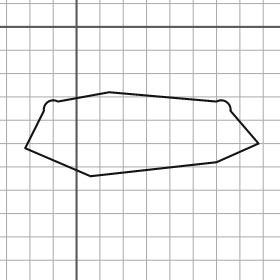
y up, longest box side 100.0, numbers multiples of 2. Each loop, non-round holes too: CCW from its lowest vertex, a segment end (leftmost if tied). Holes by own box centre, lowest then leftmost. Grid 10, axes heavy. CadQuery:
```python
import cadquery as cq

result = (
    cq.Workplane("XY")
    .moveTo(6.0, -64.0)
    .lineTo(60.0, -58.0)
    .lineTo(78.0, -50.0)
    .lineTo(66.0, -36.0)
    .threePointArc((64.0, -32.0), (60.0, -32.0))
    .lineTo(14.0, -28.0)
    .lineTo(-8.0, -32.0)
    .threePointArc((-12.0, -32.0), (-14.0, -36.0))
    .lineTo(-22.0, -52.0)
    .close()
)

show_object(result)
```